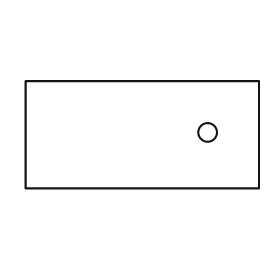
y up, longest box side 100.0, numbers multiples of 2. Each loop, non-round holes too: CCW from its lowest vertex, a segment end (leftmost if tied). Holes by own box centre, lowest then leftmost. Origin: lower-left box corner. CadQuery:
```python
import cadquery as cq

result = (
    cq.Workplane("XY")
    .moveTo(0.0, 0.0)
    .lineTo(100.0, 0.0)
    .lineTo(100.0, 46.0)
    .lineTo(0.0, 46.0)
    .close()
    .moveTo(78.0, 24.0)
    .circle(4.0)
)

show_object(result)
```